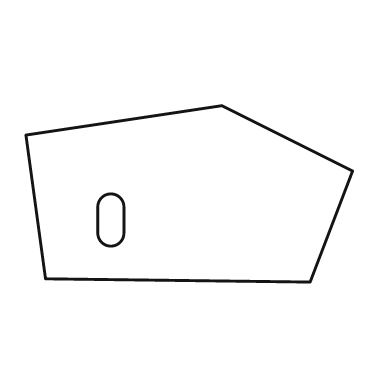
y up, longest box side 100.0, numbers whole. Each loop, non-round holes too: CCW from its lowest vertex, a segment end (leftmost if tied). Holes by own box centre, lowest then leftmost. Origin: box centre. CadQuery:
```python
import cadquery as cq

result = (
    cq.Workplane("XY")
    .moveTo(37.0, -27.0)
    .lineTo(50.0, 7.0)
    .lineTo(10.0, 27.0)
    .lineTo(-50.0, 18.0)
    .lineTo(-44.0, -26.0)
    .close()
    .moveTo(-28.0, -12.0)
    .threePointArc((-24.0, -16.0), (-20.0, -12.0))
    .lineTo(-20.0, -4.0)
    .threePointArc((-24.0, 0.0), (-28.0, -4.0))
    .close()
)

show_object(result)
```